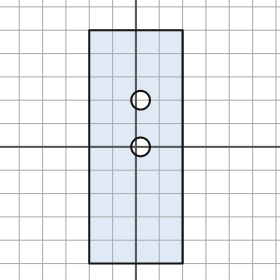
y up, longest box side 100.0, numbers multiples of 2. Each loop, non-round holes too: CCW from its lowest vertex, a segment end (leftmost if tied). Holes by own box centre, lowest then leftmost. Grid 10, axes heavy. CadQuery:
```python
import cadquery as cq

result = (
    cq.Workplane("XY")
    .moveTo(-20.0, -50.0)
    .lineTo(20.0, -50.0)
    .lineTo(20.0, 50.0)
    .lineTo(-20.0, 50.0)
    .close()
    .moveTo(2.0, 0.0)
    .circle(4.0)
    .moveTo(2.0, 20.0)
    .circle(4.0)
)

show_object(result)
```